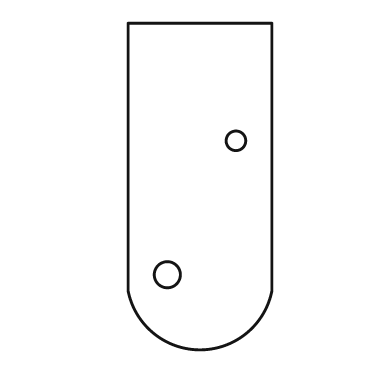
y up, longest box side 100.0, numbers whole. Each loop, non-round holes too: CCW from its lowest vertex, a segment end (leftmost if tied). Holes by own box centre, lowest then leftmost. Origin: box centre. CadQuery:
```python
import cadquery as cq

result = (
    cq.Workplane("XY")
    .moveTo(-22.0, -32.0)
    .threePointArc((0.0, -50.0), (22.0, -32.0))
    .lineTo(22.0, 50.0)
    .lineTo(-22.0, 50.0)
    .close()
    .moveTo(-10.0, -27.0)
    .circle(4.0)
    .moveTo(11.0, 14.0)
    .circle(3.0)
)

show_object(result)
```